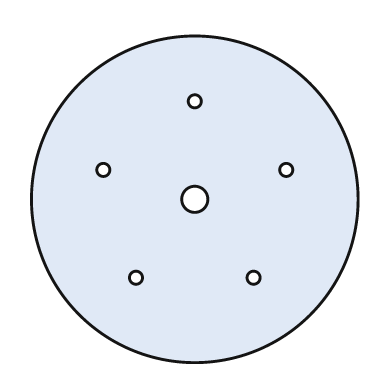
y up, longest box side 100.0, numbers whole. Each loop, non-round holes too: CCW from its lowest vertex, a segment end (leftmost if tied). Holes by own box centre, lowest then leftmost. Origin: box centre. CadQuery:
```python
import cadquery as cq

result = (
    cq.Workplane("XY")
    .moveTo(0.0, 0.0)
    .circle(50.0)
    .moveTo(-18.0, -24.0)
    .circle(2.0)
    .moveTo(18.0, -24.0)
    .circle(2.0)
    .moveTo(0.0, 0.0)
    .circle(4.0)
    .moveTo(-28.0, 9.0)
    .circle(2.0)
    .moveTo(28.0, 9.0)
    .circle(2.0)
    .moveTo(0.0, 30.0)
    .circle(2.0)
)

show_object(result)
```